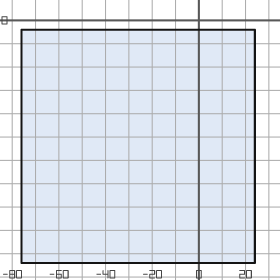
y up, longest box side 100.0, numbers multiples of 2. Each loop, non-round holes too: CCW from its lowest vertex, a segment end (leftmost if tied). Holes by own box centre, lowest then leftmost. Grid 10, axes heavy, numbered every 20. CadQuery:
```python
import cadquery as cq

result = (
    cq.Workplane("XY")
    .moveTo(-76.0, -104.0)
    .lineTo(24.0, -104.0)
    .lineTo(24.0, -4.0)
    .lineTo(-76.0, -4.0)
    .close()
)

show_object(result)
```